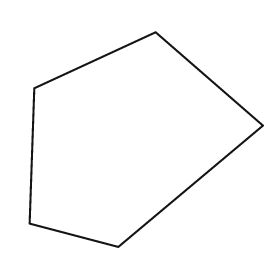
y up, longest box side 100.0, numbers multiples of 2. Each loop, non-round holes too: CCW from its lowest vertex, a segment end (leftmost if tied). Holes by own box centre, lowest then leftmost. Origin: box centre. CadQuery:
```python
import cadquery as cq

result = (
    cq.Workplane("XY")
    .moveTo(-12.0, -46.0)
    .lineTo(50.0, 6.0)
    .lineTo(4.0, 46.0)
    .lineTo(-48.0, 22.0)
    .lineTo(-50.0, -36.0)
    .close()
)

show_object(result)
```